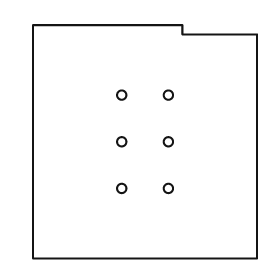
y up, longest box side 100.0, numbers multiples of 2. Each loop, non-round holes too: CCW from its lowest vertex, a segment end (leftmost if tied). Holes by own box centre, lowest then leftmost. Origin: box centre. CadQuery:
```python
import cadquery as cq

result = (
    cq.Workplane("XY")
    .moveTo(-48.0, -50.0)
    .lineTo(48.0, -50.0)
    .lineTo(48.0, 46.0)
    .lineTo(16.0, 46.0)
    .lineTo(16.0, 50.0)
    .lineTo(-48.0, 50.0)
    .close()
    .moveTo(-10.0, -20.0)
    .circle(2.0)
    .moveTo(10.0, -20.0)
    .circle(2.0)
    .moveTo(-10.0, 0.0)
    .circle(2.0)
    .moveTo(10.0, 0.0)
    .circle(2.0)
    .moveTo(-10.0, 20.0)
    .circle(2.0)
    .moveTo(10.0, 20.0)
    .circle(2.0)
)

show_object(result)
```